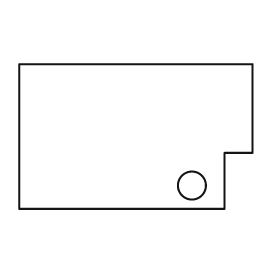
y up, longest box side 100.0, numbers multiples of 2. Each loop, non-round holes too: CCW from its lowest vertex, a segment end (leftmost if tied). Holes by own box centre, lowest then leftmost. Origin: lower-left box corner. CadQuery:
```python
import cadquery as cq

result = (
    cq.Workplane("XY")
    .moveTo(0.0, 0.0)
    .lineTo(88.0, 0.0)
    .lineTo(88.0, 24.0)
    .lineTo(100.0, 24.0)
    .lineTo(100.0, 62.0)
    .lineTo(0.0, 62.0)
    .close()
    .moveTo(74.0, 10.0)
    .circle(6.0)
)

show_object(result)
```